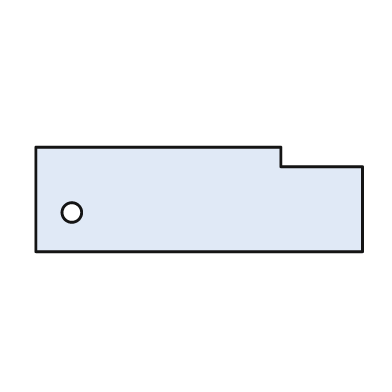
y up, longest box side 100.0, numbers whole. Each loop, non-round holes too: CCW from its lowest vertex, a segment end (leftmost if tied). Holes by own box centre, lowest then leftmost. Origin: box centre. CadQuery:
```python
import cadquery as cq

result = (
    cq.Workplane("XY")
    .moveTo(-50.0, -16.0)
    .lineTo(50.0, -16.0)
    .lineTo(50.0, 10.0)
    .lineTo(25.0, 10.0)
    .lineTo(25.0, 16.0)
    .lineTo(-50.0, 16.0)
    .close()
    .moveTo(-39.0, -4.0)
    .circle(3.0)
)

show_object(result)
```